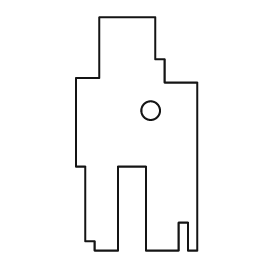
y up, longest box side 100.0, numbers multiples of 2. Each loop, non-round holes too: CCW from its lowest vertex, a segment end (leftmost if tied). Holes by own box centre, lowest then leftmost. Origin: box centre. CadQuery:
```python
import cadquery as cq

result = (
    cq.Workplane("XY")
    .moveTo(-18.0, -50.0)
    .lineTo(-8.0, -50.0)
    .lineTo(-8.0, -14.0)
    .lineTo(4.0, -14.0)
    .lineTo(4.0, -50.0)
    .lineTo(18.0, -50.0)
    .lineTo(18.0, -38.0)
    .lineTo(22.0, -38.0)
    .lineTo(22.0, -50.0)
    .lineTo(26.0, -50.0)
    .lineTo(26.0, 22.0)
    .lineTo(12.0, 22.0)
    .lineTo(12.0, 32.0)
    .lineTo(8.0, 32.0)
    .lineTo(8.0, 50.0)
    .lineTo(-16.0, 50.0)
    .lineTo(-16.0, 24.0)
    .lineTo(-26.0, 24.0)
    .lineTo(-26.0, -14.0)
    .lineTo(-22.0, -14.0)
    .lineTo(-22.0, -46.0)
    .lineTo(-18.0, -46.0)
    .close()
    .moveTo(6.0, 10.0)
    .circle(4.0)
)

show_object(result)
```